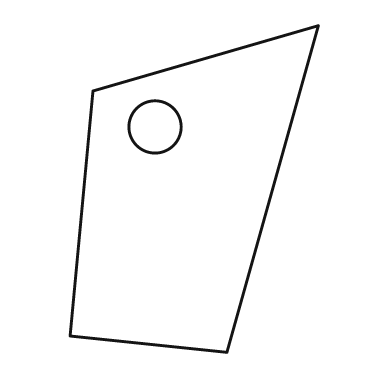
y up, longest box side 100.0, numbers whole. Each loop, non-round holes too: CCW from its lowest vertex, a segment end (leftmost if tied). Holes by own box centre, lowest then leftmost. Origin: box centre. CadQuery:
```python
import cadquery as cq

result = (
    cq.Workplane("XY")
    .moveTo(10.0, -50.0)
    .lineTo(38.0, 50.0)
    .lineTo(-31.0, 30.0)
    .lineTo(-38.0, -45.0)
    .close()
    .moveTo(-12.0, 19.0)
    .circle(8.0)
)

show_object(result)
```